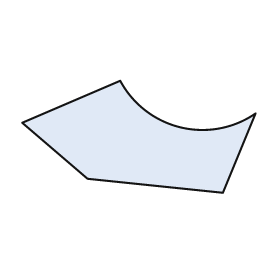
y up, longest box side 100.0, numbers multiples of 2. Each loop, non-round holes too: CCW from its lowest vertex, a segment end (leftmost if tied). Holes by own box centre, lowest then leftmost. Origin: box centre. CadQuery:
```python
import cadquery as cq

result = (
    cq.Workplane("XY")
    .moveTo(36.0, -24.0)
    .lineTo(50.0, 10.0)
    .threePointArc((18.0, 4.0), (-8.0, 24.0))
    .lineTo(-50.0, 6.0)
    .lineTo(-22.0, -18.0)
    .close()
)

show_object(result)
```